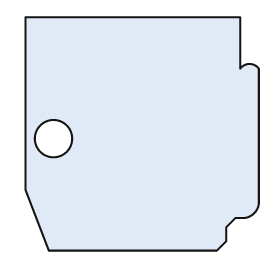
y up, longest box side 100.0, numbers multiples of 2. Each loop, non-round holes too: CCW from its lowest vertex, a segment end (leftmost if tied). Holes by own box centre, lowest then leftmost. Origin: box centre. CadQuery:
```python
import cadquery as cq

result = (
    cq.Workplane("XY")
    .moveTo(-40.0, -50.0)
    .lineTo(32.0, -50.0)
    .lineTo(36.0, -46.0)
    .lineTo(36.0, -40.0)
    .lineTo(40.0, -36.0)
    .lineTo(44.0, -36.0)
    .threePointArc((48.0, -34.0), (50.0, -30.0))
    .lineTo(50.0, 28.0)
    .threePointArc((46.0, 30.0), (42.0, 28.0))
    .lineTo(42.0, 50.0)
    .lineTo(-50.0, 50.0)
    .lineTo(-50.0, -24.0)
    .close()
    .moveTo(-38.0, -2.0)
    .circle(8.0)
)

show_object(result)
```